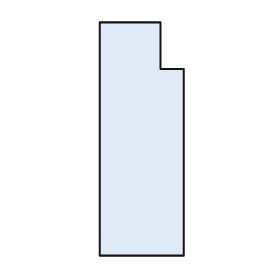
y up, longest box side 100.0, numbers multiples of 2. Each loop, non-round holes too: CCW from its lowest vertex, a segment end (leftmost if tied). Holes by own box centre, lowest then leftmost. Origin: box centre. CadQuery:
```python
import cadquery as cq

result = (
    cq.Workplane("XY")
    .moveTo(-18.0, -50.0)
    .lineTo(18.0, -50.0)
    .lineTo(18.0, 30.0)
    .lineTo(8.0, 30.0)
    .lineTo(8.0, 50.0)
    .lineTo(-18.0, 50.0)
    .close()
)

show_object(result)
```